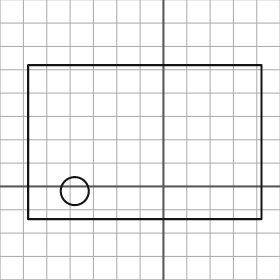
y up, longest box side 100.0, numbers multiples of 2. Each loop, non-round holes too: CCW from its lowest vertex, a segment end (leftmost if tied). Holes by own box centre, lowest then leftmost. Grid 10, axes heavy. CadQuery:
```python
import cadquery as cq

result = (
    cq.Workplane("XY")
    .moveTo(-58.0, -14.0)
    .lineTo(42.0, -14.0)
    .lineTo(42.0, 52.0)
    .lineTo(-58.0, 52.0)
    .close()
    .moveTo(-38.0, -2.0)
    .circle(6.0)
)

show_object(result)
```